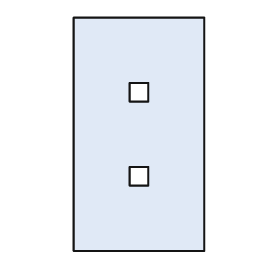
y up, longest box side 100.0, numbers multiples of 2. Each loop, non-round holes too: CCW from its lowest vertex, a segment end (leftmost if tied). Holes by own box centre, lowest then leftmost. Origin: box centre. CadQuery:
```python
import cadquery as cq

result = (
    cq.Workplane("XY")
    .moveTo(-28.0, -50.0)
    .lineTo(28.0, -50.0)
    .lineTo(28.0, 50.0)
    .lineTo(-28.0, 50.0)
    .close()
    .moveTo(-4.0, -22.0)
    .lineTo(4.0, -22.0)
    .lineTo(4.0, -14.0)
    .lineTo(-4.0, -14.0)
    .close()
    .moveTo(-4.0, 14.0)
    .lineTo(4.0, 14.0)
    .lineTo(4.0, 22.0)
    .lineTo(-4.0, 22.0)
    .close()
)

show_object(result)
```